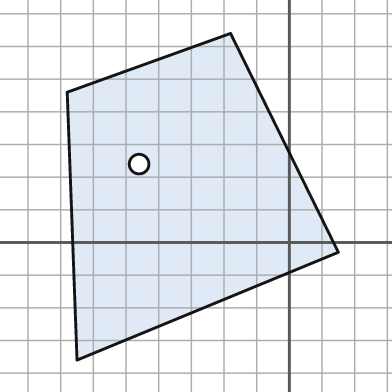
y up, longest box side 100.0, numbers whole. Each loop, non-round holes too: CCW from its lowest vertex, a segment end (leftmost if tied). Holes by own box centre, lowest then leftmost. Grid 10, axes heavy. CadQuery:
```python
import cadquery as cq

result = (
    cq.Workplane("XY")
    .moveTo(-65.0, -36.0)
    .lineTo(15.0, -3.0)
    .lineTo(-18.0, 64.0)
    .lineTo(-68.0, 46.0)
    .close()
    .moveTo(-46.0, 24.0)
    .circle(3.0)
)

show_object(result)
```